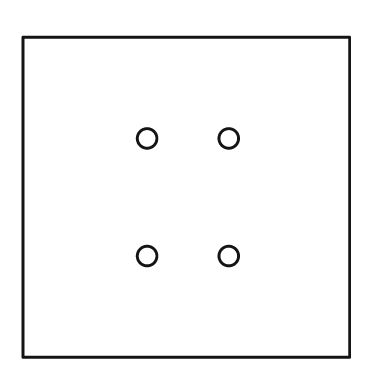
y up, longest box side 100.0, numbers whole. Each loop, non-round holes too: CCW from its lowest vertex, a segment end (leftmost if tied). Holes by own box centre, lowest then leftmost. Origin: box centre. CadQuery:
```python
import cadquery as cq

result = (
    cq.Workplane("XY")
    .moveTo(-50.0, -49.0)
    .lineTo(50.0, -49.0)
    .lineTo(50.0, 49.0)
    .lineTo(-50.0, 49.0)
    .close()
    .moveTo(-12.0, -18.0)
    .circle(3.0)
    .moveTo(13.0, -18.0)
    .circle(3.0)
    .moveTo(-12.0, 18.0)
    .circle(3.0)
    .moveTo(13.0, 18.0)
    .circle(3.0)
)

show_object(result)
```